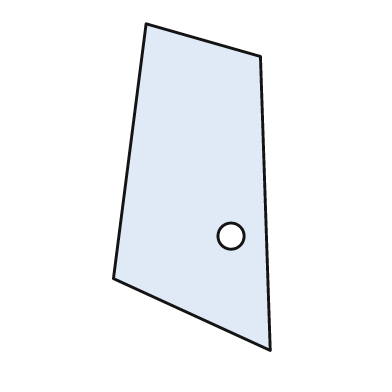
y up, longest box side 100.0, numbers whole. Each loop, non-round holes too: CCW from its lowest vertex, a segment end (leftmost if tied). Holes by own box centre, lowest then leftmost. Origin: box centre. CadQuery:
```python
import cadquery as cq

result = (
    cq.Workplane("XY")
    .moveTo(24.0, -50.0)
    .lineTo(21.0, 40.0)
    .lineTo(-14.0, 50.0)
    .lineTo(-24.0, -28.0)
    .close()
    .moveTo(12.0, -15.0)
    .circle(4.0)
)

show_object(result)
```